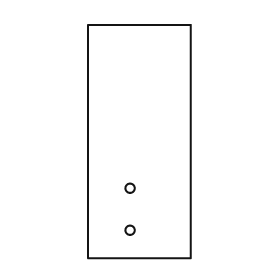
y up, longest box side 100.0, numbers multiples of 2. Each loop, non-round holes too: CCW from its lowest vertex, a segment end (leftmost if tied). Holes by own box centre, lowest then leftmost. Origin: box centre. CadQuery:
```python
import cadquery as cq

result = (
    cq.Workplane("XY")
    .moveTo(-22.0, -50.0)
    .lineTo(22.0, -50.0)
    .lineTo(22.0, 50.0)
    .lineTo(-22.0, 50.0)
    .close()
    .moveTo(-4.0, -38.0)
    .circle(2.0)
    .moveTo(-4.0, -20.0)
    .circle(2.0)
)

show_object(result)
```